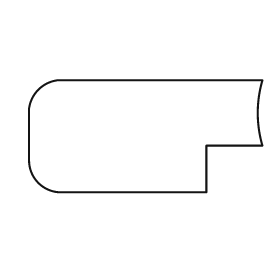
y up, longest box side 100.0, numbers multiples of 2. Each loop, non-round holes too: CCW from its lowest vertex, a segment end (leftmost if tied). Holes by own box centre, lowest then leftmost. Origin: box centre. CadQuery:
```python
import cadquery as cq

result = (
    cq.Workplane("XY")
    .moveTo(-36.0, -24.0)
    .lineTo(26.0, -24.0)
    .lineTo(26.0, -4.0)
    .lineTo(50.0, -4.0)
    .threePointArc((48.0, 10.0), (50.0, 24.0))
    .lineTo(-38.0, 24.0)
    .threePointArc((-46.0, 20.0), (-50.0, 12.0))
    .lineTo(-50.0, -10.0)
    .threePointArc((-46.0, -20.0), (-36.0, -24.0))
    .close()
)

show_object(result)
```